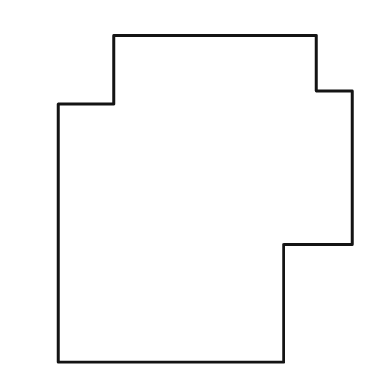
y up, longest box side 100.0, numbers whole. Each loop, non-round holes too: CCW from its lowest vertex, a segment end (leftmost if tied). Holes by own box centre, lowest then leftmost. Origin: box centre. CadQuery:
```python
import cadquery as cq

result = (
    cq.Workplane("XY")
    .moveTo(-45.0, -50.0)
    .lineTo(24.0, -50.0)
    .lineTo(24.0, -14.0)
    .lineTo(45.0, -14.0)
    .lineTo(45.0, 33.0)
    .lineTo(34.0, 33.0)
    .lineTo(34.0, 50.0)
    .lineTo(-28.0, 50.0)
    .lineTo(-28.0, 29.0)
    .lineTo(-45.0, 29.0)
    .close()
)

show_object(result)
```